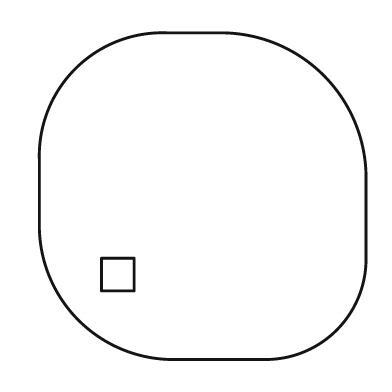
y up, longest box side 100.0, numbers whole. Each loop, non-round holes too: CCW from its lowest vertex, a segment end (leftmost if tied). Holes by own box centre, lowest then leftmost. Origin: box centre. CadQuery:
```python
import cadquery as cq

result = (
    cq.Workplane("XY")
    .moveTo(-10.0, -50.0)
    .lineTo(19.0, -50.0)
    .threePointArc((41.0, -41.0), (50.0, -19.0))
    .lineTo(50.0, 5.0)
    .threePointArc((37.0, 37.0), (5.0, 50.0))
    .lineTo(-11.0, 50.0)
    .threePointArc((-39.0, 39.0), (-50.0, 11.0))
    .lineTo(-50.0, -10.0)
    .threePointArc((-38.0, -38.0), (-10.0, -50.0))
    .close()
    .moveTo(-31.0, -29.0)
    .lineTo(-21.0, -29.0)
    .lineTo(-21.0, -19.0)
    .lineTo(-31.0, -19.0)
    .close()
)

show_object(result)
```